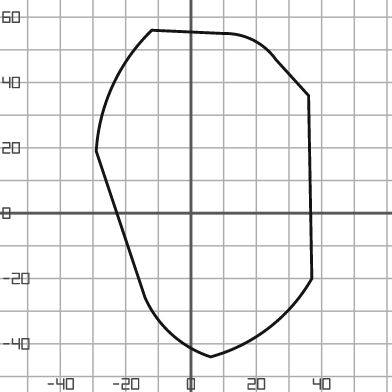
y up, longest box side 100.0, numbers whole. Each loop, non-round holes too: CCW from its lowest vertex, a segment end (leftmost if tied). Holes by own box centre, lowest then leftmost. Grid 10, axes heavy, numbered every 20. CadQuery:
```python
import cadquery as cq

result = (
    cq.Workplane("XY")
    .moveTo(6.0, -44.0)
    .threePointArc((24.0, -35.0), (37.0, -20.0))
    .lineTo(36.0, 36.0)
    .lineTo(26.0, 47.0)
    .threePointArc((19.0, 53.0), (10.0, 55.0))
    .lineTo(-12.0, 56.0)
    .threePointArc((-24.0, 39.0), (-29.0, 19.0))
    .lineTo(-14.0, -26.0)
    .threePointArc((-6.0, -37.0), (6.0, -44.0))
    .close()
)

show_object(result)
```